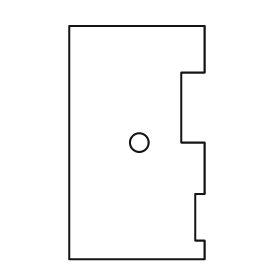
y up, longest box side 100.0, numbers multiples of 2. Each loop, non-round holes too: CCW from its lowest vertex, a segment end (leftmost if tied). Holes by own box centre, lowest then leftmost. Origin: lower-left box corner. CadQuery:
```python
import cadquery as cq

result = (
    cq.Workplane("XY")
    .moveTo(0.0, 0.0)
    .lineTo(58.0, 0.0)
    .lineTo(58.0, 8.0)
    .lineTo(54.0, 8.0)
    .lineTo(54.0, 28.0)
    .lineTo(58.0, 28.0)
    .lineTo(58.0, 50.0)
    .lineTo(48.0, 50.0)
    .lineTo(48.0, 80.0)
    .lineTo(58.0, 80.0)
    .lineTo(58.0, 100.0)
    .lineTo(0.0, 100.0)
    .close()
    .moveTo(30.0, 50.0)
    .circle(4.0)
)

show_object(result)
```